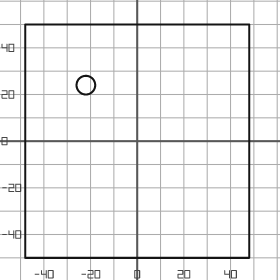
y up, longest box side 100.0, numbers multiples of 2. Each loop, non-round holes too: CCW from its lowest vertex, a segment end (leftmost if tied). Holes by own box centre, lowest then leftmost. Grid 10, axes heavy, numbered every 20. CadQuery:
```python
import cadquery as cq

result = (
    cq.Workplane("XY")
    .moveTo(-48.0, -50.0)
    .lineTo(48.0, -50.0)
    .lineTo(48.0, 50.0)
    .lineTo(-48.0, 50.0)
    .close()
    .moveTo(-22.0, 24.0)
    .circle(4.0)
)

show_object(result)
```